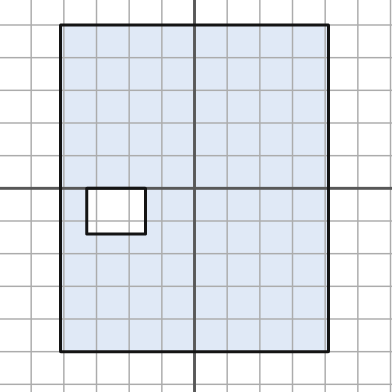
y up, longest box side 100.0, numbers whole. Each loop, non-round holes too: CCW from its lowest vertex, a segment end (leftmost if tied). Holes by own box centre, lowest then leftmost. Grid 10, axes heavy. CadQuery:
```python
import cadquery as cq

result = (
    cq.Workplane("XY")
    .moveTo(-41.0, -50.0)
    .lineTo(41.0, -50.0)
    .lineTo(41.0, 50.0)
    .lineTo(-41.0, 50.0)
    .close()
    .moveTo(-33.0, -14.0)
    .lineTo(-15.0, -14.0)
    .lineTo(-15.0, 0.0)
    .lineTo(-33.0, 0.0)
    .close()
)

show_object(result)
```